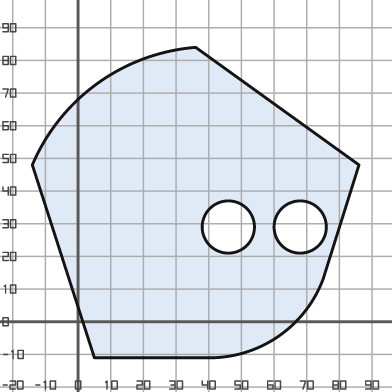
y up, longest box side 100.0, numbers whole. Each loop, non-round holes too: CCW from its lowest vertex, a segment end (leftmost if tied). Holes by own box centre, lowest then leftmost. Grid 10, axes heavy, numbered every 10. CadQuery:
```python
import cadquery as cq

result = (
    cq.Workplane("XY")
    .moveTo(5.0, -11.0)
    .lineTo(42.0, -11.0)
    .threePointArc((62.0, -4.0), (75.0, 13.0))
    .lineTo(86.0, 48.0)
    .lineTo(36.0, 84.0)
    .threePointArc((6.0, 73.0), (-14.0, 48.0))
    .close()
    .moveTo(46.0, 29.0)
    .circle(8.0)
    .moveTo(68.0, 29.0)
    .circle(8.0)
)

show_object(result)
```